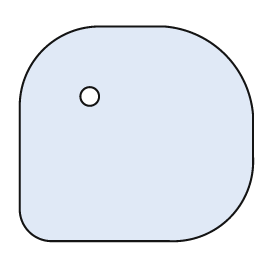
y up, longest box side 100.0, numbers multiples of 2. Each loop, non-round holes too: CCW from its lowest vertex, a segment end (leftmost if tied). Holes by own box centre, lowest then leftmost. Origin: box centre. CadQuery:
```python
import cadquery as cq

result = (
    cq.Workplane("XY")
    .moveTo(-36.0, -46.0)
    .lineTo(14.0, -46.0)
    .threePointArc((40.0, -36.0), (50.0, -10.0))
    .lineTo(50.0, 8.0)
    .threePointArc((38.0, 34.0), (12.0, 46.0))
    .lineTo(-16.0, 46.0)
    .threePointArc((-40.0, 36.0), (-50.0, 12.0))
    .lineTo(-50.0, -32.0)
    .threePointArc((-46.0, -42.0), (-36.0, -46.0))
    .close()
    .moveTo(-20.0, 16.0)
    .circle(4.0)
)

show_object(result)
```